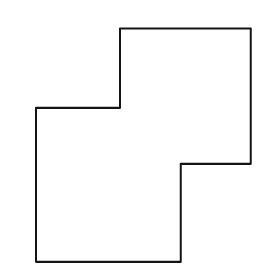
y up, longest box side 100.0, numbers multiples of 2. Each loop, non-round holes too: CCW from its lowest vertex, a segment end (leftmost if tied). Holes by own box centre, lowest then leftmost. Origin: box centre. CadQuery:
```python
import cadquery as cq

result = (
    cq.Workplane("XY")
    .moveTo(-46.0, -50.0)
    .lineTo(16.0, -50.0)
    .lineTo(16.0, -8.0)
    .lineTo(46.0, -8.0)
    .lineTo(46.0, 50.0)
    .lineTo(-10.0, 50.0)
    .lineTo(-10.0, 16.0)
    .lineTo(-46.0, 16.0)
    .close()
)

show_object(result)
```